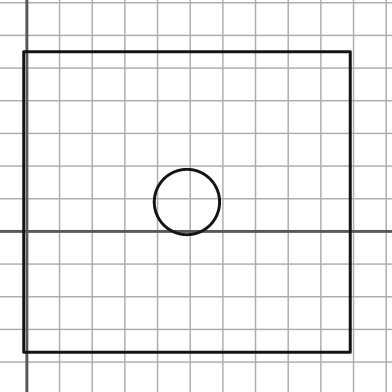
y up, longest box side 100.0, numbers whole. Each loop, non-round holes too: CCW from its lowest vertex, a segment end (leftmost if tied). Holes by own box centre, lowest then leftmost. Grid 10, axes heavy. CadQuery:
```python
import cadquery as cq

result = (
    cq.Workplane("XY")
    .moveTo(-1.0, -37.0)
    .lineTo(99.0, -37.0)
    .lineTo(99.0, 55.0)
    .lineTo(-1.0, 55.0)
    .close()
    .moveTo(49.0, 9.0)
    .circle(10.0)
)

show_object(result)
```